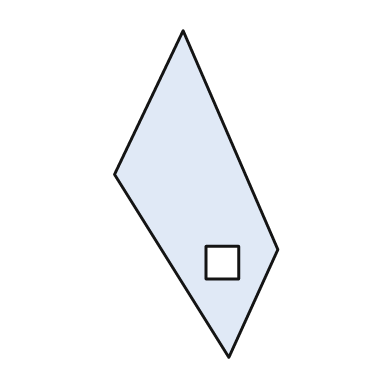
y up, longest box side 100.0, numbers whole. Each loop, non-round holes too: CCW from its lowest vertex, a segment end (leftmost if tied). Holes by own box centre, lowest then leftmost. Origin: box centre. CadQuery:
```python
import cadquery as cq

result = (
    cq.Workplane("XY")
    .moveTo(10.0, -50.0)
    .lineTo(25.0, -17.0)
    .lineTo(-4.0, 50.0)
    .lineTo(-25.0, 6.0)
    .close()
    .moveTo(3.0, -26.0)
    .lineTo(13.0, -26.0)
    .lineTo(13.0, -16.0)
    .lineTo(3.0, -16.0)
    .close()
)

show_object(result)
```